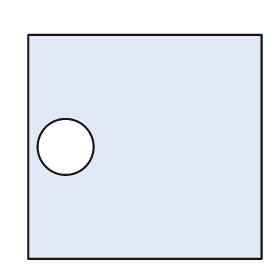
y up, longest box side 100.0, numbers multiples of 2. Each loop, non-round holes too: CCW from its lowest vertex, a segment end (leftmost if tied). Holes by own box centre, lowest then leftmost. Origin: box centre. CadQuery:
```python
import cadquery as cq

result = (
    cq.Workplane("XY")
    .moveTo(-50.0, -48.0)
    .lineTo(50.0, -48.0)
    .lineTo(50.0, 48.0)
    .lineTo(-50.0, 48.0)
    .close()
    .moveTo(-34.0, 0.0)
    .circle(12.0)
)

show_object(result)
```